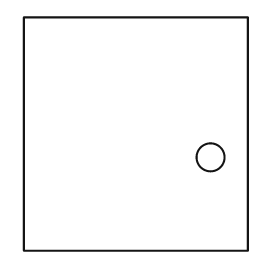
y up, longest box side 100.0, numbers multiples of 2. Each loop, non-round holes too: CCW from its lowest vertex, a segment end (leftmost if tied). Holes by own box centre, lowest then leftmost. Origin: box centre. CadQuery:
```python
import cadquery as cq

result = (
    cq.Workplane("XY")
    .moveTo(-48.0, -50.0)
    .lineTo(48.0, -50.0)
    .lineTo(48.0, 50.0)
    .lineTo(-48.0, 50.0)
    .close()
    .moveTo(32.0, -10.0)
    .circle(6.0)
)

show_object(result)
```